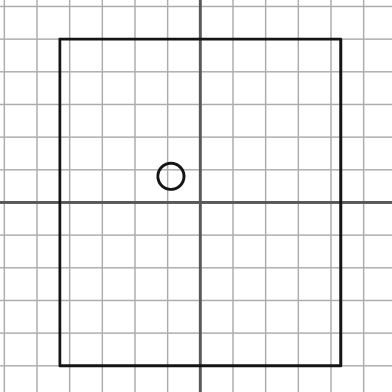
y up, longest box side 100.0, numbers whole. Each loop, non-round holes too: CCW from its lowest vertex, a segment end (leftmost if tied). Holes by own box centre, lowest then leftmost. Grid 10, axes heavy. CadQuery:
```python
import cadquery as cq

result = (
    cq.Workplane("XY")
    .moveTo(-43.0, -50.0)
    .lineTo(43.0, -50.0)
    .lineTo(43.0, 50.0)
    .lineTo(-43.0, 50.0)
    .close()
    .moveTo(-9.0, 8.0)
    .circle(4.0)
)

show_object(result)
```